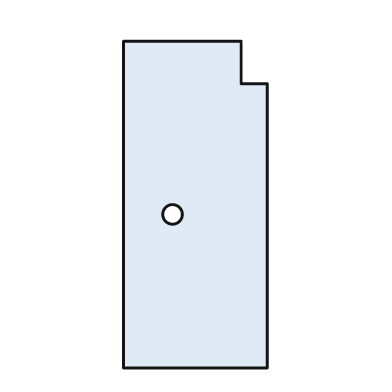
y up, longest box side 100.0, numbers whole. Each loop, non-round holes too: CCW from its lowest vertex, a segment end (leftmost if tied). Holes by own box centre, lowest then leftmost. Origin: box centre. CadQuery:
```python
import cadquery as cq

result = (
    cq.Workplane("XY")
    .moveTo(-22.0, -50.0)
    .lineTo(22.0, -50.0)
    .lineTo(22.0, 37.0)
    .lineTo(14.0, 37.0)
    .lineTo(14.0, 50.0)
    .lineTo(-22.0, 50.0)
    .close()
    .moveTo(-7.0, -3.0)
    .circle(3.0)
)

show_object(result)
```